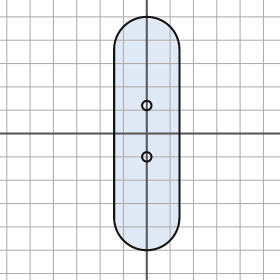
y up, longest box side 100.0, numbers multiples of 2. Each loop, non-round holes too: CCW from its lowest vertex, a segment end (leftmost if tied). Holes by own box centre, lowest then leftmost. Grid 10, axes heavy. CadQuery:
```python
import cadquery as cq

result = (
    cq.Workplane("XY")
    .moveTo(-14.0, -36.0)
    .threePointArc((0.0, -50.0), (14.0, -36.0))
    .lineTo(14.0, 36.0)
    .threePointArc((0.0, 50.0), (-14.0, 36.0))
    .close()
    .moveTo(0.0, -10.0)
    .circle(2.0)
    .moveTo(0.0, 12.0)
    .circle(2.0)
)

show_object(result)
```